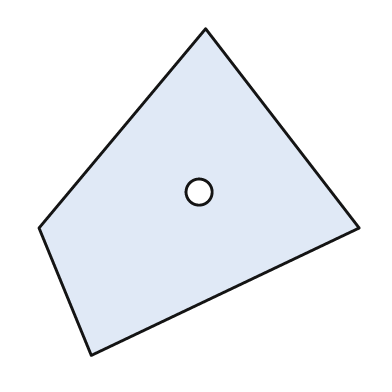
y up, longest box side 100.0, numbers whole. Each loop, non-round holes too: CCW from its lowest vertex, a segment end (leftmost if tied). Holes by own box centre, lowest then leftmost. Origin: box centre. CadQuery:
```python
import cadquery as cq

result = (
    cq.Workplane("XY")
    .moveTo(-33.0, -50.0)
    .lineTo(49.0, -11.0)
    .lineTo(2.0, 50.0)
    .lineTo(-49.0, -11.0)
    .close()
    .moveTo(0.0, 0.0)
    .circle(4.0)
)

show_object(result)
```